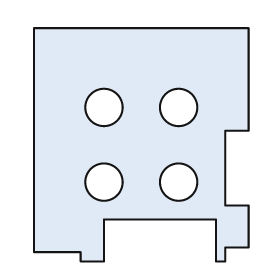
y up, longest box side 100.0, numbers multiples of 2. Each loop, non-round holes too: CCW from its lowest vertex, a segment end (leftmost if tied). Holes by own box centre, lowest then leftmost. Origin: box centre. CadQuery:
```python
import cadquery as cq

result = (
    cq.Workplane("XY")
    .moveTo(-26.0, -50.0)
    .lineTo(-16.0, -50.0)
    .lineTo(-16.0, -32.0)
    .lineTo(32.0, -32.0)
    .lineTo(32.0, -50.0)
    .lineTo(36.0, -50.0)
    .lineTo(36.0, -44.0)
    .lineTo(46.0, -44.0)
    .lineTo(46.0, -26.0)
    .lineTo(36.0, -26.0)
    .lineTo(36.0, 6.0)
    .lineTo(46.0, 6.0)
    .lineTo(46.0, 50.0)
    .lineTo(-46.0, 50.0)
    .lineTo(-46.0, -46.0)
    .lineTo(-26.0, -46.0)
    .close()
    .moveTo(-16.0, -16.0)
    .circle(8.0)
    .moveTo(16.0, -16.0)
    .circle(8.0)
    .moveTo(-16.0, 16.0)
    .circle(8.0)
    .moveTo(16.0, 16.0)
    .circle(8.0)
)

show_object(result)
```